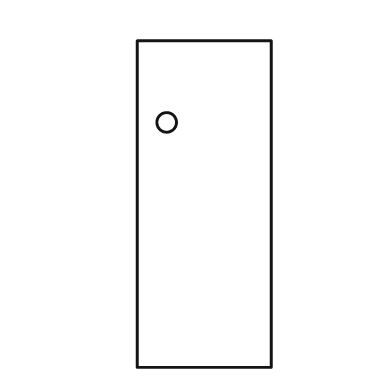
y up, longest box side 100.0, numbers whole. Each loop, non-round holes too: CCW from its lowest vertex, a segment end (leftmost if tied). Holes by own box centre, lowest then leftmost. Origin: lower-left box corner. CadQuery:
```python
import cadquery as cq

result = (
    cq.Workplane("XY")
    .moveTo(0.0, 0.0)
    .lineTo(41.0, 0.0)
    .lineTo(41.0, 100.0)
    .lineTo(0.0, 100.0)
    .close()
    .moveTo(9.0, 75.0)
    .circle(3.0)
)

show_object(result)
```